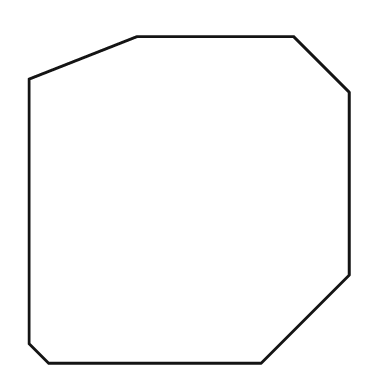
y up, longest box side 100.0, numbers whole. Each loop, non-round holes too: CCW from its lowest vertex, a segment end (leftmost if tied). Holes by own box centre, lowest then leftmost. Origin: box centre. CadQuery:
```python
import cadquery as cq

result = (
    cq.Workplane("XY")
    .moveTo(-43.0, -50.0)
    .lineTo(22.0, -50.0)
    .lineTo(49.0, -23.0)
    .lineTo(49.0, 33.0)
    .lineTo(32.0, 50.0)
    .lineTo(-16.0, 50.0)
    .lineTo(-49.0, 37.0)
    .lineTo(-49.0, -44.0)
    .close()
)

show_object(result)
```